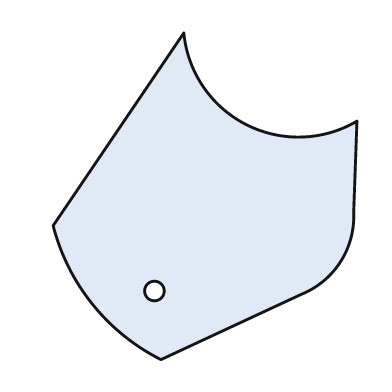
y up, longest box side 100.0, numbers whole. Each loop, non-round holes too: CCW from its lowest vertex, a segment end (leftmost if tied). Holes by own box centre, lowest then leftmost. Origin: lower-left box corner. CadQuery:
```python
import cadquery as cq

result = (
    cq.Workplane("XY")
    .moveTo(33.0, 0.0)
    .lineTo(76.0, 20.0)
    .threePointArc((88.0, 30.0), (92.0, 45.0))
    .lineTo(93.0, 73.0)
    .threePointArc((59.0, 72.0), (40.0, 100.0))
    .lineTo(0.0, 41.0)
    .threePointArc((12.0, 17.0), (33.0, 0.0))
    .close()
    .moveTo(31.0, 21.0)
    .circle(3.0)
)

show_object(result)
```